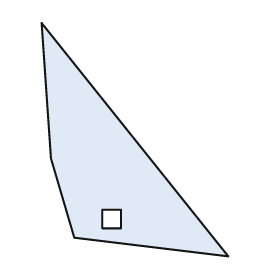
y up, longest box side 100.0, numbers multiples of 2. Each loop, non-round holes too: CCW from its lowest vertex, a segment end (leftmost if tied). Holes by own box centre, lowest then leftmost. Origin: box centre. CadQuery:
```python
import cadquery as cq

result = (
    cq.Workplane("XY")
    .moveTo(40.0, -50.0)
    .lineTo(-40.0, 50.0)
    .lineTo(-36.0, -8.0)
    .lineTo(-26.0, -42.0)
    .close()
    .moveTo(-14.0, -38.0)
    .lineTo(-6.0, -38.0)
    .lineTo(-6.0, -30.0)
    .lineTo(-14.0, -30.0)
    .close()
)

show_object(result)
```